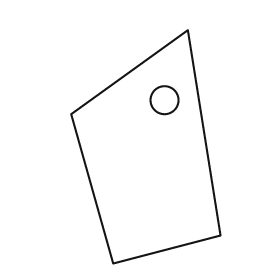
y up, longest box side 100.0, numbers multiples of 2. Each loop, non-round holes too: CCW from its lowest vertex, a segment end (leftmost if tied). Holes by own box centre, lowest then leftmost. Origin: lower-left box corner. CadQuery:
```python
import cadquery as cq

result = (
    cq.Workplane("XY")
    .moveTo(18.0, 0.0)
    .lineTo(64.0, 12.0)
    .lineTo(50.0, 100.0)
    .lineTo(0.0, 64.0)
    .close()
    .moveTo(40.0, 70.0)
    .circle(6.0)
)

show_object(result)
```